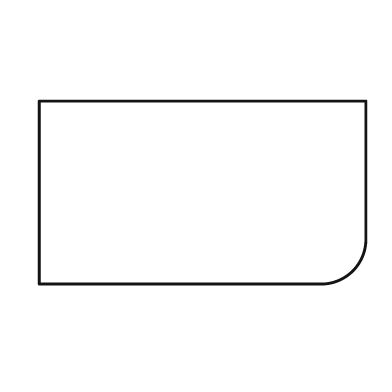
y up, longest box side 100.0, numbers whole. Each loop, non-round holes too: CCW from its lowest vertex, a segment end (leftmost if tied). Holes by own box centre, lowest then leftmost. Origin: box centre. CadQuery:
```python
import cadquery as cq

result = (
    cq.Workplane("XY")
    .moveTo(-50.0, -28.0)
    .lineTo(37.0, -28.0)
    .threePointArc((46.0, -24.0), (50.0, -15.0))
    .lineTo(50.0, 28.0)
    .lineTo(-50.0, 28.0)
    .close()
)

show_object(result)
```